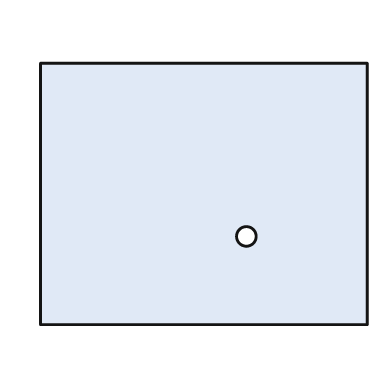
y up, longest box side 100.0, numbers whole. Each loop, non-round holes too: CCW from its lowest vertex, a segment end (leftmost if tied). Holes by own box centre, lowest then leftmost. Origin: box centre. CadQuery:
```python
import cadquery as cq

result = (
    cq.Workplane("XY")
    .moveTo(-50.0, -40.0)
    .lineTo(50.0, -40.0)
    .lineTo(50.0, 40.0)
    .lineTo(-50.0, 40.0)
    .close()
    .moveTo(13.0, -13.0)
    .circle(3.0)
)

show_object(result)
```